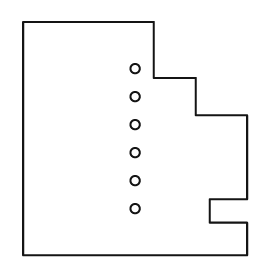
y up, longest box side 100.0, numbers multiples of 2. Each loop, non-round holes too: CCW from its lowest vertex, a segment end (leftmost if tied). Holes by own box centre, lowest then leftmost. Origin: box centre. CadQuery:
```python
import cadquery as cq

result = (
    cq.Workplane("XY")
    .moveTo(-48.0, -50.0)
    .lineTo(48.0, -50.0)
    .lineTo(48.0, -36.0)
    .lineTo(32.0, -36.0)
    .lineTo(32.0, -26.0)
    .lineTo(48.0, -26.0)
    .lineTo(48.0, 10.0)
    .lineTo(26.0, 10.0)
    .lineTo(26.0, 26.0)
    .lineTo(8.0, 26.0)
    .lineTo(8.0, 50.0)
    .lineTo(-48.0, 50.0)
    .close()
    .moveTo(0.0, -30.0)
    .circle(2.0)
    .moveTo(0.0, -18.0)
    .circle(2.0)
    .moveTo(0.0, -6.0)
    .circle(2.0)
    .moveTo(0.0, 6.0)
    .circle(2.0)
    .moveTo(0.0, 18.0)
    .circle(2.0)
    .moveTo(0.0, 30.0)
    .circle(2.0)
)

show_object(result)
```